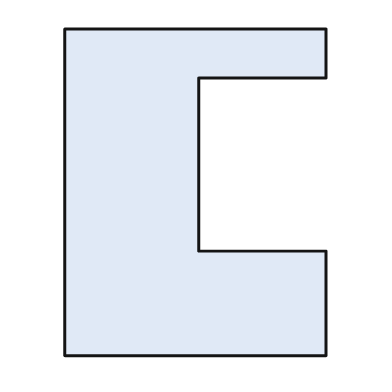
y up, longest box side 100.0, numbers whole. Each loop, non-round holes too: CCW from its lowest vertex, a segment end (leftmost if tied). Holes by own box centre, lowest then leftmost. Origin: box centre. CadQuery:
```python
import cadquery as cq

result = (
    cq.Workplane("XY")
    .moveTo(-40.0, -50.0)
    .lineTo(40.0, -50.0)
    .lineTo(40.0, -18.0)
    .lineTo(1.0, -18.0)
    .lineTo(1.0, 35.0)
    .lineTo(40.0, 35.0)
    .lineTo(40.0, 50.0)
    .lineTo(-40.0, 50.0)
    .close()
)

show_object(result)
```